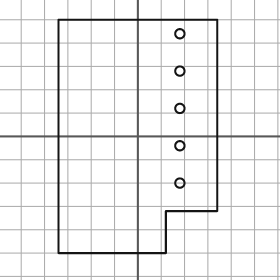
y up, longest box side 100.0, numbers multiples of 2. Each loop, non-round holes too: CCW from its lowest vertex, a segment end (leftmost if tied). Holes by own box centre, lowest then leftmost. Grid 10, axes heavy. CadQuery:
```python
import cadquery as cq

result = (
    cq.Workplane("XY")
    .moveTo(-34.0, -50.0)
    .lineTo(12.0, -50.0)
    .lineTo(12.0, -32.0)
    .lineTo(34.0, -32.0)
    .lineTo(34.0, 50.0)
    .lineTo(-34.0, 50.0)
    .close()
    .moveTo(18.0, -20.0)
    .circle(2.0)
    .moveTo(18.0, -4.0)
    .circle(2.0)
    .moveTo(18.0, 12.0)
    .circle(2.0)
    .moveTo(18.0, 28.0)
    .circle(2.0)
    .moveTo(18.0, 44.0)
    .circle(2.0)
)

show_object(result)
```